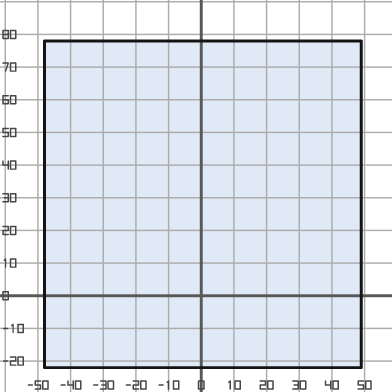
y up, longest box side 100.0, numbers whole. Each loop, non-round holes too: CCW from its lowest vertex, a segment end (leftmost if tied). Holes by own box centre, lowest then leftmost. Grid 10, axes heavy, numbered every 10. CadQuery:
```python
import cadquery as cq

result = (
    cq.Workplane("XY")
    .moveTo(-48.0, -22.0)
    .lineTo(49.0, -22.0)
    .lineTo(49.0, 78.0)
    .lineTo(-48.0, 78.0)
    .close()
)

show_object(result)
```